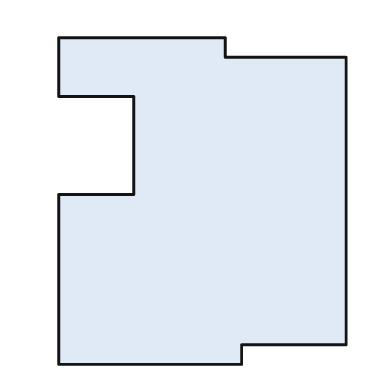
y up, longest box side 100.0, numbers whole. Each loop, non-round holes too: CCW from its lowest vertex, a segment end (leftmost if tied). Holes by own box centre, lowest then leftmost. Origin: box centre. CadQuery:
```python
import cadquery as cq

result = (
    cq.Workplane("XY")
    .moveTo(-44.0, -50.0)
    .lineTo(12.0, -50.0)
    .lineTo(12.0, -44.0)
    .lineTo(44.0, -44.0)
    .lineTo(44.0, 44.0)
    .lineTo(7.0, 44.0)
    .lineTo(7.0, 50.0)
    .lineTo(-44.0, 50.0)
    .lineTo(-44.0, 32.0)
    .lineTo(-21.0, 32.0)
    .lineTo(-21.0, 2.0)
    .lineTo(-44.0, 2.0)
    .close()
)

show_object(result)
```